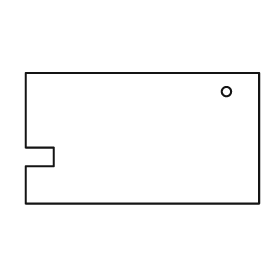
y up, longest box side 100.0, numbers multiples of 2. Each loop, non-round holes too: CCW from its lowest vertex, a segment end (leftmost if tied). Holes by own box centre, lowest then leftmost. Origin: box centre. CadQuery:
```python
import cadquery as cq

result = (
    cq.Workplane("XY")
    .moveTo(-50.0, -28.0)
    .lineTo(50.0, -28.0)
    .lineTo(50.0, 28.0)
    .lineTo(-50.0, 28.0)
    .lineTo(-50.0, -4.0)
    .lineTo(-38.0, -4.0)
    .lineTo(-38.0, -12.0)
    .lineTo(-50.0, -12.0)
    .close()
    .moveTo(36.0, 20.0)
    .circle(2.0)
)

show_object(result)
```